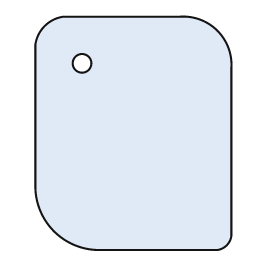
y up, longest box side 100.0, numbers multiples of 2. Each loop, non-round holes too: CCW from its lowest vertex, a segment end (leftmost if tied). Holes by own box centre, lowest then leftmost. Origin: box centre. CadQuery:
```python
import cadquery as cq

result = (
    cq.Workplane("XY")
    .moveTo(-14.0, -50.0)
    .lineTo(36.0, -50.0)
    .threePointArc((40.0, -48.0), (42.0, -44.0))
    .lineTo(42.0, 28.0)
    .threePointArc((36.0, 44.0), (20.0, 50.0))
    .lineTo(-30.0, 50.0)
    .threePointArc((-38.0, 46.0), (-42.0, 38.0))
    .lineTo(-42.0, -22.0)
    .threePointArc((-34.0, -42.0), (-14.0, -50.0))
    .close()
    .moveTo(-22.0, 30.0)
    .circle(4.0)
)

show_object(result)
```